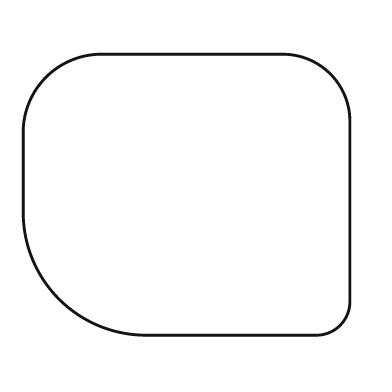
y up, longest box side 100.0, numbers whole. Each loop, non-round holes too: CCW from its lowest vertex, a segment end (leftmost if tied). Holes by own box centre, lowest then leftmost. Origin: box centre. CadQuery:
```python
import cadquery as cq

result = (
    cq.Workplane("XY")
    .moveTo(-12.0, -43.0)
    .lineTo(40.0, -43.0)
    .threePointArc((47.0, -40.0), (50.0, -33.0))
    .lineTo(50.0, 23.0)
    .threePointArc((44.0, 37.0), (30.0, 43.0))
    .lineTo(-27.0, 43.0)
    .threePointArc((-43.0, 36.0), (-50.0, 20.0))
    .lineTo(-50.0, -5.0)
    .threePointArc((-39.0, -32.0), (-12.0, -43.0))
    .close()
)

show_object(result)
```